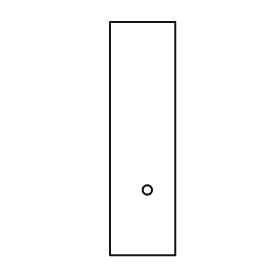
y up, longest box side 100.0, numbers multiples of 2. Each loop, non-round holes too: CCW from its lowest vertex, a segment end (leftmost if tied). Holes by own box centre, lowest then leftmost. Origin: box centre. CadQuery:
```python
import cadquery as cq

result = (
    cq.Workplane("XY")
    .moveTo(-14.0, -50.0)
    .lineTo(14.0, -50.0)
    .lineTo(14.0, 50.0)
    .lineTo(-14.0, 50.0)
    .close()
    .moveTo(2.0, -22.0)
    .circle(2.0)
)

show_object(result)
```